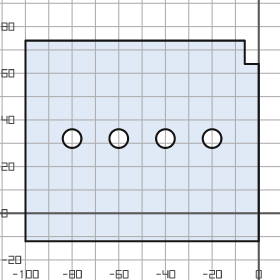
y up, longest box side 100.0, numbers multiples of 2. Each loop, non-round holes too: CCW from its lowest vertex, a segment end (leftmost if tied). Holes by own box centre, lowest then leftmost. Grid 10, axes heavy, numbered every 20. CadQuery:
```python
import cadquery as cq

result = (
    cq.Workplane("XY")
    .moveTo(-100.0, -12.0)
    .lineTo(0.0, -12.0)
    .lineTo(0.0, 64.0)
    .lineTo(-6.0, 64.0)
    .lineTo(-6.0, 74.0)
    .lineTo(-100.0, 74.0)
    .close()
    .moveTo(-80.0, 32.0)
    .circle(4.0)
    .moveTo(-60.0, 32.0)
    .circle(4.0)
    .moveTo(-40.0, 32.0)
    .circle(4.0)
    .moveTo(-20.0, 32.0)
    .circle(4.0)
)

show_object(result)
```